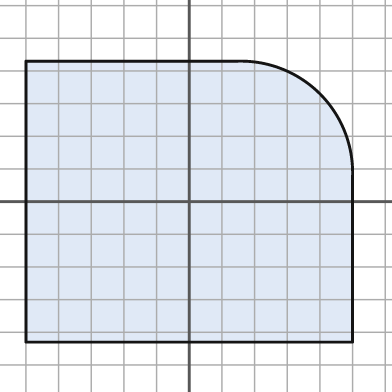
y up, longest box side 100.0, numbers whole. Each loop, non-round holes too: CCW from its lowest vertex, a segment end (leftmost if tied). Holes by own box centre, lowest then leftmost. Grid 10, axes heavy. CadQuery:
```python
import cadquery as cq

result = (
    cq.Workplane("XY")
    .moveTo(-50.0, -43.0)
    .lineTo(50.0, -43.0)
    .lineTo(50.0, 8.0)
    .threePointArc((40.0, 33.0), (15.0, 43.0))
    .lineTo(-50.0, 43.0)
    .close()
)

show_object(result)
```